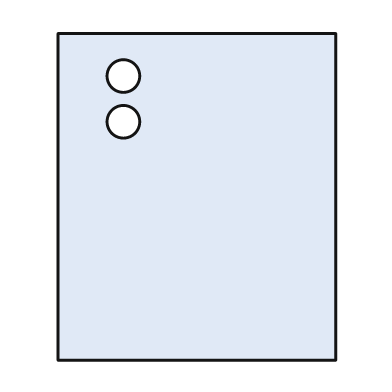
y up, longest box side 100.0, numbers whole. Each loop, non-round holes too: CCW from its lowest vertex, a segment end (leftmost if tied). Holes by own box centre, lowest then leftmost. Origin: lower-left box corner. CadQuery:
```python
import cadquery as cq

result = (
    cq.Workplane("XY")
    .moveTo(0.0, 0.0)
    .lineTo(85.0, 0.0)
    .lineTo(85.0, 100.0)
    .lineTo(0.0, 100.0)
    .close()
    .moveTo(20.0, 73.0)
    .circle(5.0)
    .moveTo(20.0, 87.0)
    .circle(5.0)
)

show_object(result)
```